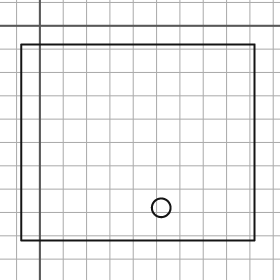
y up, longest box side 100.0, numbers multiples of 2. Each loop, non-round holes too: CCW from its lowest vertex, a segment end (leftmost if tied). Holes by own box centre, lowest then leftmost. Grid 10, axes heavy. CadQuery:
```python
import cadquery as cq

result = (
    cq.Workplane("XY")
    .moveTo(-8.0, -92.0)
    .lineTo(92.0, -92.0)
    .lineTo(92.0, -8.0)
    .lineTo(-8.0, -8.0)
    .close()
    .moveTo(52.0, -78.0)
    .circle(4.0)
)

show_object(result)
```